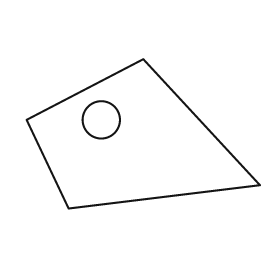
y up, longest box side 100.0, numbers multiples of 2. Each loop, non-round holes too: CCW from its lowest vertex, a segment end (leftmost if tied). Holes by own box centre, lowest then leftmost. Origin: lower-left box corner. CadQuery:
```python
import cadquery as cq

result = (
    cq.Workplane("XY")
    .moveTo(18.0, 0.0)
    .lineTo(100.0, 10.0)
    .lineTo(50.0, 64.0)
    .lineTo(0.0, 38.0)
    .close()
    .moveTo(32.0, 38.0)
    .circle(8.0)
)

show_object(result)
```